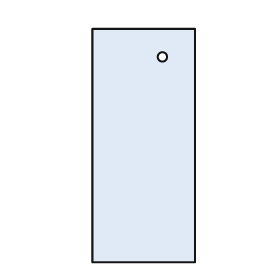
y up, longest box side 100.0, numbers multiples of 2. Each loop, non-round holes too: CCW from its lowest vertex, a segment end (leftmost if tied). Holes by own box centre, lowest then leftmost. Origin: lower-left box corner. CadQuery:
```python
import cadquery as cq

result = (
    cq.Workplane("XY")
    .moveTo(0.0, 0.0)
    .lineTo(44.0, 0.0)
    .lineTo(44.0, 100.0)
    .lineTo(0.0, 100.0)
    .close()
    .moveTo(30.0, 88.0)
    .circle(2.0)
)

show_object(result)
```